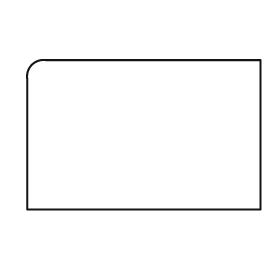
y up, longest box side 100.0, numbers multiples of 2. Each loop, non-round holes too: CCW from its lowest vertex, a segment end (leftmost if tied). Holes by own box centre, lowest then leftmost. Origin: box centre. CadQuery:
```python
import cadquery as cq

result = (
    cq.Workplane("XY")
    .moveTo(-50.0, -32.0)
    .lineTo(50.0, -32.0)
    .lineTo(50.0, 32.0)
    .lineTo(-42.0, 32.0)
    .threePointArc((-48.0, 30.0), (-50.0, 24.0))
    .close()
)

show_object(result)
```